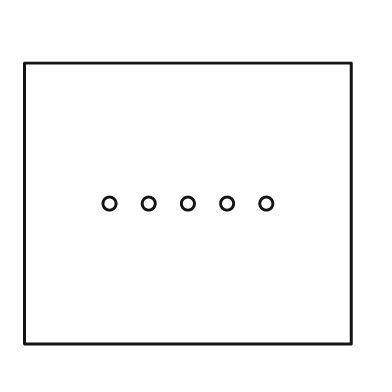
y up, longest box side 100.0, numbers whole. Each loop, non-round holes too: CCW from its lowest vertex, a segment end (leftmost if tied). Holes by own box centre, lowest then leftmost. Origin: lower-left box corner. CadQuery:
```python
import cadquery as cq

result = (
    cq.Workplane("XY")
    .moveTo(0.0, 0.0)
    .lineTo(100.0, 0.0)
    .lineTo(100.0, 86.0)
    .lineTo(0.0, 86.0)
    .close()
    .moveTo(26.0, 43.0)
    .circle(2.0)
    .moveTo(38.0, 43.0)
    .circle(2.0)
    .moveTo(50.0, 43.0)
    .circle(2.0)
    .moveTo(62.0, 43.0)
    .circle(2.0)
    .moveTo(74.0, 43.0)
    .circle(2.0)
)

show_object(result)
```